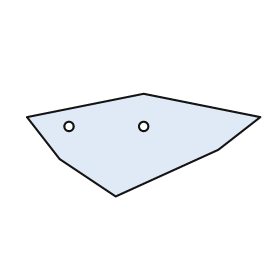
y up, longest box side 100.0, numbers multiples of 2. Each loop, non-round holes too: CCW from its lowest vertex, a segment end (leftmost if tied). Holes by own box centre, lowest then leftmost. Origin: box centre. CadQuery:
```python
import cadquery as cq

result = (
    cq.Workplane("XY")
    .moveTo(-12.0, -22.0)
    .lineTo(32.0, -2.0)
    .lineTo(50.0, 12.0)
    .lineTo(0.0, 22.0)
    .lineTo(-50.0, 12.0)
    .lineTo(-36.0, -6.0)
    .close()
    .moveTo(-32.0, 8.0)
    .circle(2.0)
    .moveTo(0.0, 8.0)
    .circle(2.0)
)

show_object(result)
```